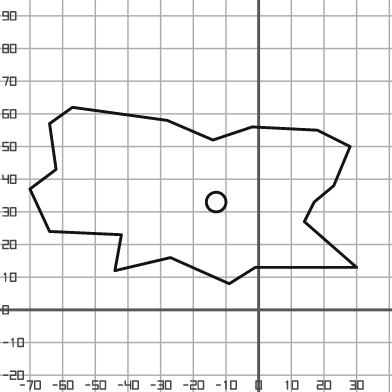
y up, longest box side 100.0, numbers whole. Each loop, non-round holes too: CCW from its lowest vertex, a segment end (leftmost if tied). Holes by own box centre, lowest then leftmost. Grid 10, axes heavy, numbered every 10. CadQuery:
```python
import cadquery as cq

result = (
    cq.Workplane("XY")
    .moveTo(-9.0, 8.0)
    .lineTo(-1.0, 13.0)
    .lineTo(30.0, 13.0)
    .lineTo(14.0, 27.0)
    .lineTo(17.0, 33.0)
    .lineTo(23.0, 38.0)
    .lineTo(28.0, 50.0)
    .lineTo(18.0, 55.0)
    .lineTo(-2.0, 56.0)
    .lineTo(-14.0, 52.0)
    .lineTo(-28.0, 58.0)
    .lineTo(-57.0, 62.0)
    .lineTo(-64.0, 57.0)
    .lineTo(-62.0, 43.0)
    .lineTo(-70.0, 37.0)
    .lineTo(-64.0, 24.0)
    .lineTo(-42.0, 23.0)
    .lineTo(-44.0, 12.0)
    .lineTo(-27.0, 16.0)
    .close()
    .moveTo(-13.0, 33.0)
    .circle(3.0)
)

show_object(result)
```